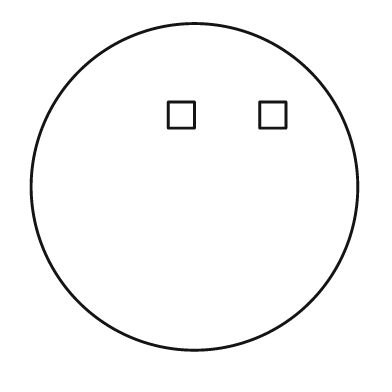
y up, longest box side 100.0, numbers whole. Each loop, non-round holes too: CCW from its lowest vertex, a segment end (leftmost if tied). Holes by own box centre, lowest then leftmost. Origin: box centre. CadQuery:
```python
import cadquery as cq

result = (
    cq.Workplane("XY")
    .moveTo(0.0, 0.0)
    .circle(50.0)
    .moveTo(-8.0, 18.0)
    .lineTo(0.0, 18.0)
    .lineTo(0.0, 26.0)
    .lineTo(-8.0, 26.0)
    .close()
    .moveTo(20.0, 18.0)
    .lineTo(28.0, 18.0)
    .lineTo(28.0, 26.0)
    .lineTo(20.0, 26.0)
    .close()
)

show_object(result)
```